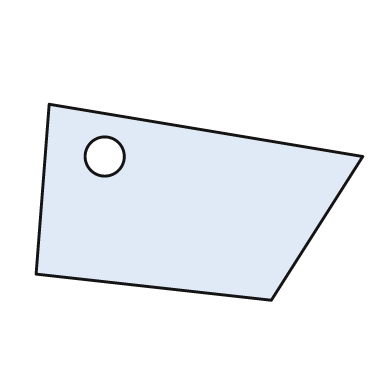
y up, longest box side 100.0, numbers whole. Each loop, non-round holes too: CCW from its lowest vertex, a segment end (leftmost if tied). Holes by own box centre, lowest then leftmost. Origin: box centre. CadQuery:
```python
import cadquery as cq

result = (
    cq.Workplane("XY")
    .moveTo(22.0, -30.0)
    .lineTo(50.0, 14.0)
    .lineTo(-46.0, 30.0)
    .lineTo(-50.0, -22.0)
    .close()
    .moveTo(-29.0, 14.0)
    .circle(6.0)
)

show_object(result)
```